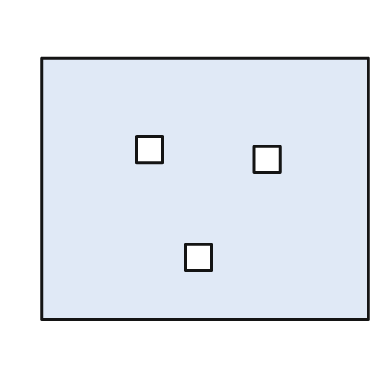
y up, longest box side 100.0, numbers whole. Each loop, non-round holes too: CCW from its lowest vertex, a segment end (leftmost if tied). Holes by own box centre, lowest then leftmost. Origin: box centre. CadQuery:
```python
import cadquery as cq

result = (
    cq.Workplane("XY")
    .moveTo(-50.0, -40.0)
    .lineTo(50.0, -40.0)
    .lineTo(50.0, 40.0)
    .lineTo(-50.0, 40.0)
    .close()
    .moveTo(-6.0, -25.0)
    .lineTo(2.0, -25.0)
    .lineTo(2.0, -17.0)
    .lineTo(-6.0, -17.0)
    .close()
    .moveTo(15.0, 5.0)
    .lineTo(23.0, 5.0)
    .lineTo(23.0, 13.0)
    .lineTo(15.0, 13.0)
    .close()
    .moveTo(-21.0, 8.0)
    .lineTo(-13.0, 8.0)
    .lineTo(-13.0, 16.0)
    .lineTo(-21.0, 16.0)
    .close()
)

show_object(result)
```